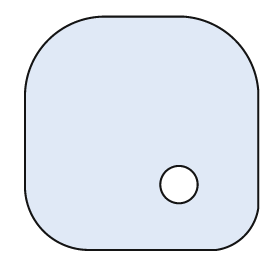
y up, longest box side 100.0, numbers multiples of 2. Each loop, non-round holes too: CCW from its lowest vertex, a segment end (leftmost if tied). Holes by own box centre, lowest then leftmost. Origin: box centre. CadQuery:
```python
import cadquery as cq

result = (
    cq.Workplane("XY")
    .moveTo(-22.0, -50.0)
    .lineTo(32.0, -50.0)
    .threePointArc((44.0, -44.0), (50.0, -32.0))
    .lineTo(50.0, 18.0)
    .threePointArc((40.0, 40.0), (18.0, 50.0))
    .lineTo(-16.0, 50.0)
    .threePointArc((-40.0, 40.0), (-50.0, 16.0))
    .lineTo(-50.0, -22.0)
    .threePointArc((-42.0, -42.0), (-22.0, -50.0))
    .close()
    .moveTo(16.0, -22.0)
    .circle(8.0)
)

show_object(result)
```